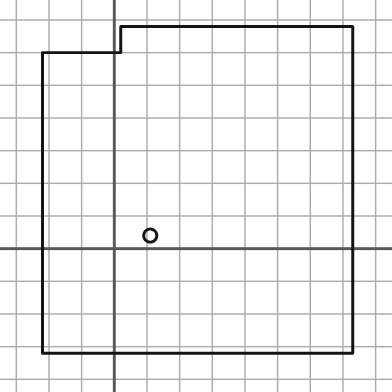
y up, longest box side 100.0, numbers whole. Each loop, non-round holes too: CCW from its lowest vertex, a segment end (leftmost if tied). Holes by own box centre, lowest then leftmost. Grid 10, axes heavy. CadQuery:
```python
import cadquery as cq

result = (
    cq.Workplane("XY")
    .moveTo(-22.0, -32.0)
    .lineTo(73.0, -32.0)
    .lineTo(73.0, 68.0)
    .lineTo(2.0, 68.0)
    .lineTo(2.0, 60.0)
    .lineTo(-22.0, 60.0)
    .close()
    .moveTo(11.0, 4.0)
    .circle(2.0)
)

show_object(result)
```